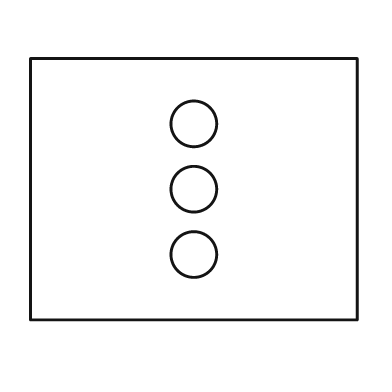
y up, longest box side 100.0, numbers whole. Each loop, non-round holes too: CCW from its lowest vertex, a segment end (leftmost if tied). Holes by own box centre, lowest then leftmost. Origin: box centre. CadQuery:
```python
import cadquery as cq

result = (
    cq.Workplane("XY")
    .moveTo(-50.0, -40.0)
    .lineTo(50.0, -40.0)
    .lineTo(50.0, 40.0)
    .lineTo(-50.0, 40.0)
    .close()
    .moveTo(0.0, -20.0)
    .circle(7.0)
    .moveTo(0.0, 0.0)
    .circle(7.0)
    .moveTo(0.0, 20.0)
    .circle(7.0)
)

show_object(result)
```